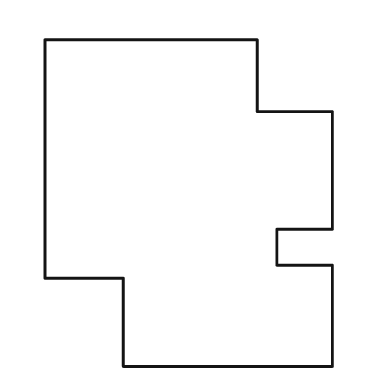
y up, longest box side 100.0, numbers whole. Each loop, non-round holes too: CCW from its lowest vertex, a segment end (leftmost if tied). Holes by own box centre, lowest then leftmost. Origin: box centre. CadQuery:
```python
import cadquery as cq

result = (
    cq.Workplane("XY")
    .moveTo(-20.0, -50.0)
    .lineTo(44.0, -50.0)
    .lineTo(44.0, -19.0)
    .lineTo(27.0, -19.0)
    .lineTo(27.0, -8.0)
    .lineTo(44.0, -8.0)
    .lineTo(44.0, 28.0)
    .lineTo(21.0, 28.0)
    .lineTo(21.0, 50.0)
    .lineTo(-44.0, 50.0)
    .lineTo(-44.0, -23.0)
    .lineTo(-20.0, -23.0)
    .close()
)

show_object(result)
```